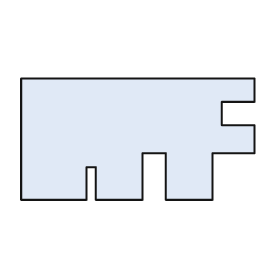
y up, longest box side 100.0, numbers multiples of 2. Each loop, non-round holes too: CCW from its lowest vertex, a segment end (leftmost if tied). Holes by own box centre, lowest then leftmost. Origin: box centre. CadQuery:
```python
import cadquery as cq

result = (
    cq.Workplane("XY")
    .moveTo(-50.0, -26.0)
    .lineTo(-22.0, -26.0)
    .lineTo(-22.0, -12.0)
    .lineTo(-18.0, -12.0)
    .lineTo(-18.0, -26.0)
    .lineTo(2.0, -26.0)
    .lineTo(2.0, -6.0)
    .lineTo(12.0, -6.0)
    .lineTo(12.0, -26.0)
    .lineTo(32.0, -26.0)
    .lineTo(32.0, -6.0)
    .lineTo(50.0, -6.0)
    .lineTo(50.0, 6.0)
    .lineTo(36.0, 6.0)
    .lineTo(36.0, 16.0)
    .lineTo(50.0, 16.0)
    .lineTo(50.0, 26.0)
    .lineTo(-50.0, 26.0)
    .close()
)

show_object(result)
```